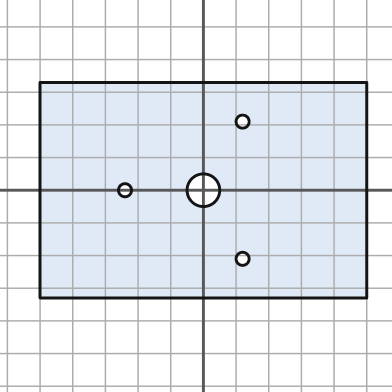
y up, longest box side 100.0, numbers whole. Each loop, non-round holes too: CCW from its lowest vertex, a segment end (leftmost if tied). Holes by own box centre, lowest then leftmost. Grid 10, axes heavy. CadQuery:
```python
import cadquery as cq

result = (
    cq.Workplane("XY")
    .moveTo(-50.0, -33.0)
    .lineTo(50.0, -33.0)
    .lineTo(50.0, 33.0)
    .lineTo(-50.0, 33.0)
    .close()
    .moveTo(12.0, -21.0)
    .circle(2.0)
    .moveTo(-24.0, 0.0)
    .circle(2.0)
    .moveTo(0.0, 0.0)
    .circle(5.0)
    .moveTo(12.0, 21.0)
    .circle(2.0)
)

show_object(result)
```